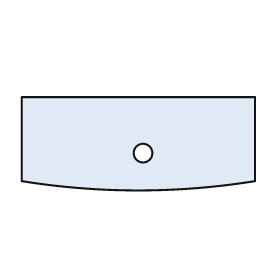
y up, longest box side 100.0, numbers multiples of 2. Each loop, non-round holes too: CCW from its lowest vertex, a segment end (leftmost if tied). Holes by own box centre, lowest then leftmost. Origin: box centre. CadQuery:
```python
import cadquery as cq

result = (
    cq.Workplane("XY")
    .moveTo(-50.0, -16.0)
    .threePointArc((0.0, -20.0), (50.0, -16.0))
    .lineTo(50.0, 20.0)
    .lineTo(-50.0, 20.0)
    .close()
    .moveTo(2.0, -4.0)
    .circle(4.0)
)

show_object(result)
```